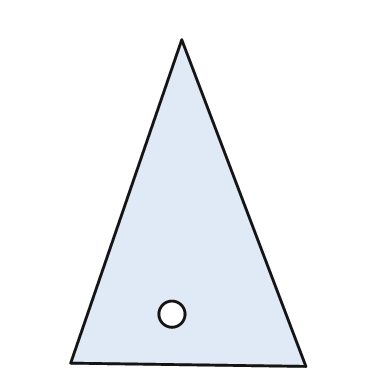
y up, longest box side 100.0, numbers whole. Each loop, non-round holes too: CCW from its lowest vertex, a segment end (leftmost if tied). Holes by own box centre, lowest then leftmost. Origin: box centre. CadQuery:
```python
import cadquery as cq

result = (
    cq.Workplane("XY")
    .moveTo(36.0, -50.0)
    .lineTo(-2.0, 50.0)
    .lineTo(-36.0, -49.0)
    .close()
    .moveTo(-5.0, -34.0)
    .circle(4.0)
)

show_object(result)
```